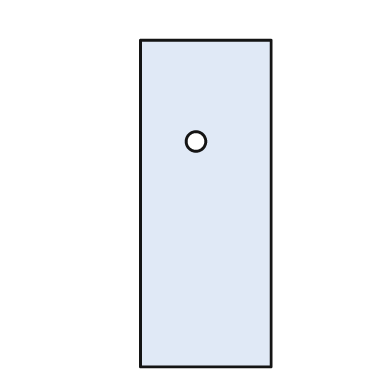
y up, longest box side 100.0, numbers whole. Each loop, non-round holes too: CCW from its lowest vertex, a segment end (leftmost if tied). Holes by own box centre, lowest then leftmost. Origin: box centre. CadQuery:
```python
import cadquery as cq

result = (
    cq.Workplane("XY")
    .moveTo(-20.0, -50.0)
    .lineTo(20.0, -50.0)
    .lineTo(20.0, 50.0)
    .lineTo(-20.0, 50.0)
    .close()
    .moveTo(-3.0, 19.0)
    .circle(3.0)
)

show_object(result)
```